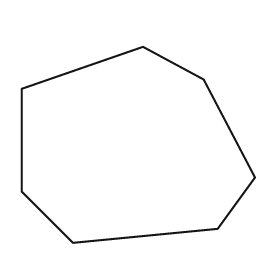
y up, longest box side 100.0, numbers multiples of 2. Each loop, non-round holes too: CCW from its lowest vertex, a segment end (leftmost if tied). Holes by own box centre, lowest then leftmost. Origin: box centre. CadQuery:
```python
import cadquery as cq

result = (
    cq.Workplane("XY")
    .moveTo(-28.0, -42.0)
    .lineTo(34.0, -36.0)
    .lineTo(50.0, -14.0)
    .lineTo(28.0, 28.0)
    .lineTo(2.0, 42.0)
    .lineTo(-50.0, 24.0)
    .lineTo(-50.0, -20.0)
    .close()
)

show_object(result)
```